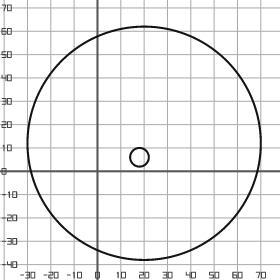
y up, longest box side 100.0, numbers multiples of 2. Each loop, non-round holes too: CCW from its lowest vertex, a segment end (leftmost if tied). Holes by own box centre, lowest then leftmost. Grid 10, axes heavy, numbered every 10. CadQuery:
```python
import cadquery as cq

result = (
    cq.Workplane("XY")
    .moveTo(20.0, 12.0)
    .circle(50.0)
    .moveTo(18.0, 6.0)
    .circle(4.0)
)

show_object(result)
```